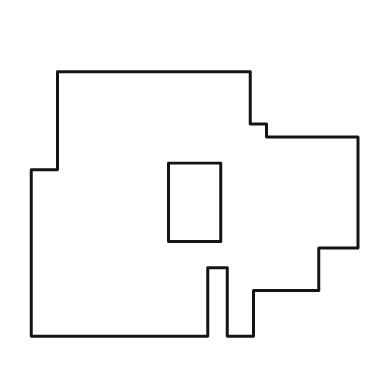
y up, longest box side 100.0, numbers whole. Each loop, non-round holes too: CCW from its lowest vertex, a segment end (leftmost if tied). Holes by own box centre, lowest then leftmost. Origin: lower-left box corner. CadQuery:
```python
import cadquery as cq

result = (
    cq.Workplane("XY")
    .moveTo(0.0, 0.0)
    .lineTo(54.0, 0.0)
    .lineTo(54.0, 21.0)
    .lineTo(60.0, 21.0)
    .lineTo(60.0, 0.0)
    .lineTo(68.0, 0.0)
    .lineTo(68.0, 14.0)
    .lineTo(88.0, 14.0)
    .lineTo(88.0, 27.0)
    .lineTo(100.0, 27.0)
    .lineTo(100.0, 61.0)
    .lineTo(72.0, 61.0)
    .lineTo(72.0, 65.0)
    .lineTo(67.0, 65.0)
    .lineTo(67.0, 81.0)
    .lineTo(8.0, 81.0)
    .lineTo(8.0, 51.0)
    .lineTo(0.0, 51.0)
    .close()
    .moveTo(42.0, 29.0)
    .lineTo(58.0, 29.0)
    .lineTo(58.0, 53.0)
    .lineTo(42.0, 53.0)
    .close()
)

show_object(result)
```